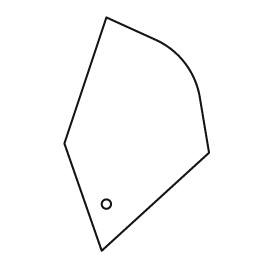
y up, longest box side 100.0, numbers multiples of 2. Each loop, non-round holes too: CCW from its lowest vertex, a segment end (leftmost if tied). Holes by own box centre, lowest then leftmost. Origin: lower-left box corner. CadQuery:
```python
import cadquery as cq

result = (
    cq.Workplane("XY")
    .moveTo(16.0, 0.0)
    .lineTo(62.0, 42.0)
    .lineTo(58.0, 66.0)
    .threePointArc((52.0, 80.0), (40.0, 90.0))
    .lineTo(18.0, 100.0)
    .lineTo(0.0, 46.0)
    .close()
    .moveTo(18.0, 20.0)
    .circle(2.0)
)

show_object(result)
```